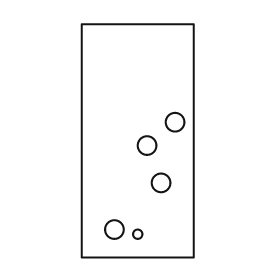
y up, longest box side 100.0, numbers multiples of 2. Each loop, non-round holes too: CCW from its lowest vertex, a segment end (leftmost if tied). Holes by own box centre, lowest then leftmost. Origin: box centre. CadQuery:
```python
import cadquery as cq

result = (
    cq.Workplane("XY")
    .moveTo(-24.0, -50.0)
    .lineTo(24.0, -50.0)
    .lineTo(24.0, 50.0)
    .lineTo(-24.0, 50.0)
    .close()
    .moveTo(0.0, -40.0)
    .circle(2.0)
    .moveTo(-10.0, -38.0)
    .circle(4.0)
    .moveTo(10.0, -18.0)
    .circle(4.0)
    .moveTo(4.0, -2.0)
    .circle(4.0)
    .moveTo(16.0, 8.0)
    .circle(4.0)
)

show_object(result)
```